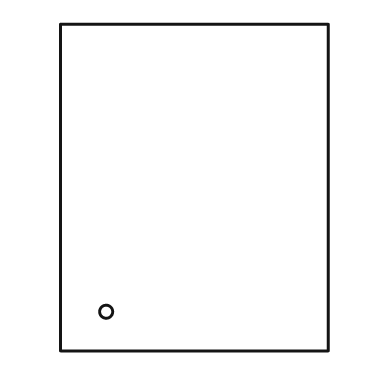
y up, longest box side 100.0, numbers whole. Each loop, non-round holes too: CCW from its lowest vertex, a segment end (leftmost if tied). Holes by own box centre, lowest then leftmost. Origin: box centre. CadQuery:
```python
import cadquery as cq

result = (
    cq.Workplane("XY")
    .moveTo(-41.0, -50.0)
    .lineTo(41.0, -50.0)
    .lineTo(41.0, 50.0)
    .lineTo(-41.0, 50.0)
    .close()
    .moveTo(-27.0, -38.0)
    .circle(2.0)
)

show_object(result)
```